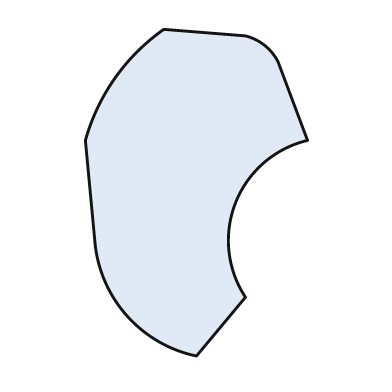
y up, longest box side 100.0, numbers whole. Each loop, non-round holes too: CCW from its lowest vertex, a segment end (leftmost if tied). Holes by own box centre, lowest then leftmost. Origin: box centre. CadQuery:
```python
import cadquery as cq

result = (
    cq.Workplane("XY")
    .moveTo(0.0, -50.0)
    .lineTo(15.0, -32.0)
    .threePointArc((12.0, -3.0), (34.0, 16.0))
    .lineTo(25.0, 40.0)
    .threePointArc((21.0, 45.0), (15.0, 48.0))
    .lineTo(-10.0, 50.0)
    .threePointArc((-25.0, 35.0), (-34.0, 16.0))
    .lineTo(-31.0, -16.0)
    .threePointArc((-21.0, -38.0), (0.0, -50.0))
    .close()
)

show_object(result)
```